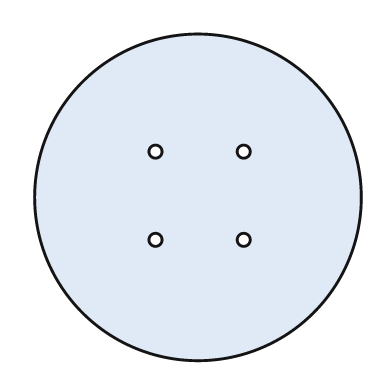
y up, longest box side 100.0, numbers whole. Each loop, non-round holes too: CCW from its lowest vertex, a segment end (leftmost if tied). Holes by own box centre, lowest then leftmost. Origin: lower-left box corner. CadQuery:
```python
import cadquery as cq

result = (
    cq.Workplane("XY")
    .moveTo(50.0, 50.0)
    .circle(50.0)
    .moveTo(37.0, 37.0)
    .circle(2.0)
    .moveTo(64.0, 37.0)
    .circle(2.0)
    .moveTo(37.0, 64.0)
    .circle(2.0)
    .moveTo(64.0, 64.0)
    .circle(2.0)
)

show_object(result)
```